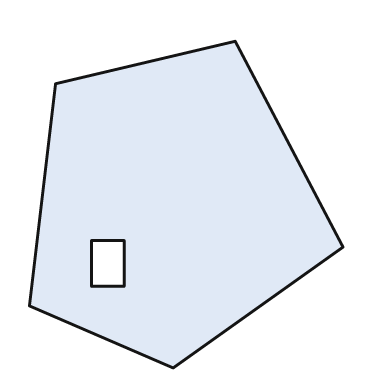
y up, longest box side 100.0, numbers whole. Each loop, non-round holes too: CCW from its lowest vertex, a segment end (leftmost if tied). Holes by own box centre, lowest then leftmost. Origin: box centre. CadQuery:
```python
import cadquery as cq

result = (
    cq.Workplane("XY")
    .moveTo(-4.0, -50.0)
    .lineTo(48.0, -13.0)
    .lineTo(15.0, 50.0)
    .lineTo(-40.0, 37.0)
    .lineTo(-48.0, -31.0)
    .close()
    .moveTo(-29.0, -25.0)
    .lineTo(-19.0, -25.0)
    .lineTo(-19.0, -11.0)
    .lineTo(-29.0, -11.0)
    .close()
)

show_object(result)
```